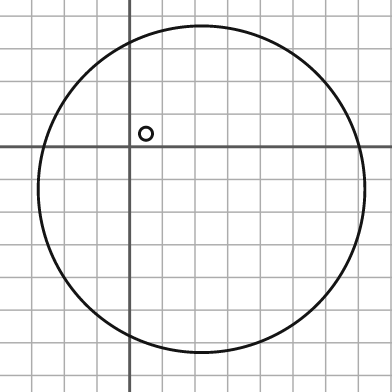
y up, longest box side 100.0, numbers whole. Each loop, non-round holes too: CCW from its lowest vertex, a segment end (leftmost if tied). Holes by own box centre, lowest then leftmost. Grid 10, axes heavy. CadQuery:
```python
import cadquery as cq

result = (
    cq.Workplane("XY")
    .moveTo(22.0, -13.0)
    .circle(50.0)
    .moveTo(5.0, 4.0)
    .circle(2.0)
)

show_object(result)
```